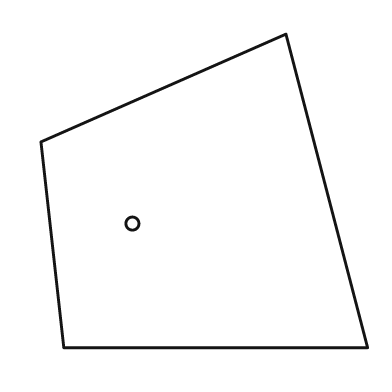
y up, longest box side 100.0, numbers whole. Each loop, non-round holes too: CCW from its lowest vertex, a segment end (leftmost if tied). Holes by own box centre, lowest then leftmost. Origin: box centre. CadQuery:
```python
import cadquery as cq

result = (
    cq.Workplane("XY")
    .moveTo(-43.0, -48.0)
    .lineTo(50.0, -48.0)
    .lineTo(25.0, 48.0)
    .lineTo(-50.0, 15.0)
    .close()
    .moveTo(-22.0, -10.0)
    .circle(2.0)
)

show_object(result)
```